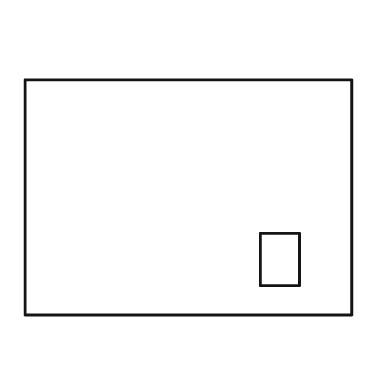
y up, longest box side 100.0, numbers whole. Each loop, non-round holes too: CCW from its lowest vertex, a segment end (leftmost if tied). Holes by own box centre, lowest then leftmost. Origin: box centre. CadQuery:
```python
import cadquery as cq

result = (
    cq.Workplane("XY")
    .moveTo(-50.0, -36.0)
    .lineTo(50.0, -36.0)
    .lineTo(50.0, 36.0)
    .lineTo(-50.0, 36.0)
    .close()
    .moveTo(22.0, -27.0)
    .lineTo(34.0, -27.0)
    .lineTo(34.0, -11.0)
    .lineTo(22.0, -11.0)
    .close()
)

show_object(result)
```